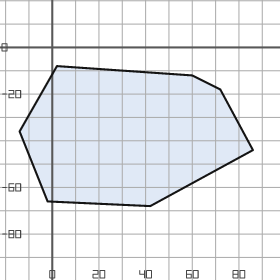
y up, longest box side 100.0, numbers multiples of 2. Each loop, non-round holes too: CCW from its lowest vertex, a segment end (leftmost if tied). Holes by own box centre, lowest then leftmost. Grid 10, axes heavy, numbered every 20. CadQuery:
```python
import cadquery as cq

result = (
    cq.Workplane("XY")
    .moveTo(42.0, -68.0)
    .lineTo(86.0, -44.0)
    .lineTo(72.0, -18.0)
    .lineTo(60.0, -12.0)
    .lineTo(2.0, -8.0)
    .lineTo(-14.0, -36.0)
    .lineTo(-2.0, -66.0)
    .close()
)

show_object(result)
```